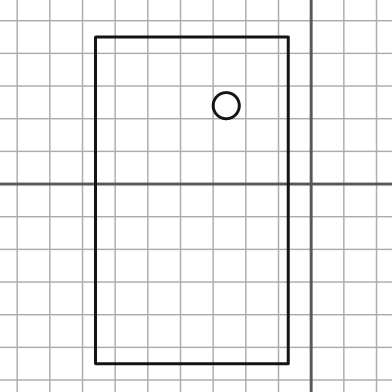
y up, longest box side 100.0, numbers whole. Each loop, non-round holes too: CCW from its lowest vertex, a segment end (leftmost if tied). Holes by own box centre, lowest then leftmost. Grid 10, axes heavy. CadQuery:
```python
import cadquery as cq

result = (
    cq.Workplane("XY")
    .moveTo(-66.0, -55.0)
    .lineTo(-7.0, -55.0)
    .lineTo(-7.0, 45.0)
    .lineTo(-66.0, 45.0)
    .close()
    .moveTo(-26.0, 24.0)
    .circle(4.0)
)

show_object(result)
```